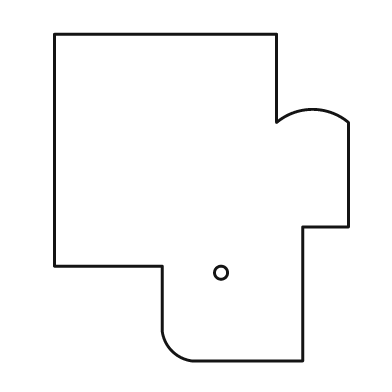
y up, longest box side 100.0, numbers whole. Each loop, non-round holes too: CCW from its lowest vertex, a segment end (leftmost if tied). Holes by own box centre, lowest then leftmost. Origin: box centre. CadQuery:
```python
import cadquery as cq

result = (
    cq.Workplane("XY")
    .moveTo(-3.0, -50.0)
    .lineTo(31.0, -50.0)
    .lineTo(31.0, -9.0)
    .lineTo(45.0, -9.0)
    .lineTo(45.0, 23.0)
    .threePointArc((34.0, 27.0), (23.0, 23.0))
    .lineTo(23.0, 50.0)
    .lineTo(-45.0, 50.0)
    .lineTo(-45.0, -21.0)
    .lineTo(-12.0, -21.0)
    .lineTo(-12.0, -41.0)
    .threePointArc((-9.0, -47.0), (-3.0, -50.0))
    .close()
    .moveTo(6.0, -23.0)
    .circle(2.0)
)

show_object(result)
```